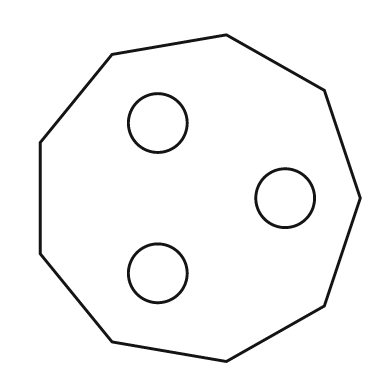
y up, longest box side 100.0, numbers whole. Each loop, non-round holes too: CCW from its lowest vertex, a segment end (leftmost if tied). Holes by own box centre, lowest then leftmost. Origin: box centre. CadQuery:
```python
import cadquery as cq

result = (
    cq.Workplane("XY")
    .moveTo(8.0, -50.0)
    .lineTo(38.0, -33.0)
    .lineTo(49.0, 0.0)
    .lineTo(38.0, 33.0)
    .lineTo(8.0, 50.0)
    .lineTo(-27.0, 44.0)
    .lineTo(-49.0, 17.0)
    .lineTo(-49.0, -17.0)
    .lineTo(-27.0, -44.0)
    .close()
    .moveTo(-13.0, -23.0)
    .circle(9.0)
    .moveTo(26.0, 0.0)
    .circle(9.0)
    .moveTo(-13.0, 23.0)
    .circle(9.0)
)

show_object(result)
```